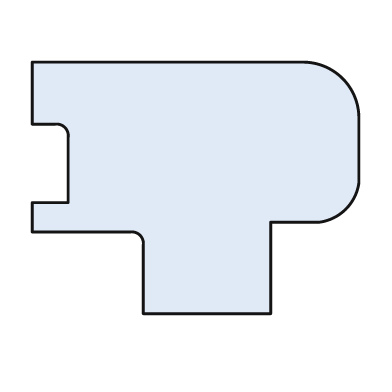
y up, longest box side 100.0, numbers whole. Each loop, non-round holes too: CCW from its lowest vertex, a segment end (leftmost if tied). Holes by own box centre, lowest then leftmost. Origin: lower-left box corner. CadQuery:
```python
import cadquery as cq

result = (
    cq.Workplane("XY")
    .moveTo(34.0, 0.0)
    .lineTo(73.0, 0.0)
    .lineTo(73.0, 28.0)
    .lineTo(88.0, 28.0)
    .threePointArc((96.0, 32.0), (100.0, 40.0))
    .lineTo(100.0, 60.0)
    .threePointArc((95.0, 72.0), (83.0, 77.0))
    .lineTo(0.0, 77.0)
    .lineTo(0.0, 58.0)
    .lineTo(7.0, 58.0)
    .threePointArc((10.0, 57.0), (11.0, 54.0))
    .lineTo(11.0, 34.0)
    .lineTo(0.0, 34.0)
    .lineTo(0.0, 25.0)
    .lineTo(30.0, 25.0)
    .threePointArc((33.0, 24.0), (34.0, 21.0))
    .close()
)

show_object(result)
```